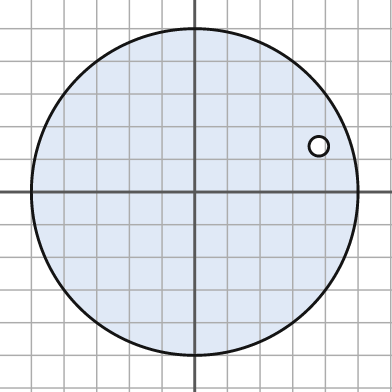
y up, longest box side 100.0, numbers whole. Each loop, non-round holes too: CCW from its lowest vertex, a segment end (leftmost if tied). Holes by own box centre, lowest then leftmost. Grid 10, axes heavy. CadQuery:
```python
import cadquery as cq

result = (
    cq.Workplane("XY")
    .moveTo(0.0, 0.0)
    .circle(50.0)
    .moveTo(38.0, 14.0)
    .circle(3.0)
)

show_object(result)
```